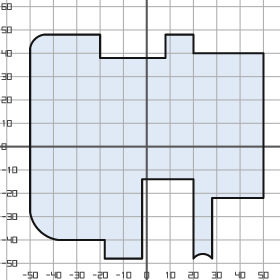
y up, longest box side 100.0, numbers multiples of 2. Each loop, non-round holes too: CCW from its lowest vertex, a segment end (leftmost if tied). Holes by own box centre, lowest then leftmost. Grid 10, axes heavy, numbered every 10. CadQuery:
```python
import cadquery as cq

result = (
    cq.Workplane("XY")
    .moveTo(-18.0, -48.0)
    .lineTo(-2.0, -48.0)
    .lineTo(-2.0, -14.0)
    .lineTo(20.0, -14.0)
    .lineTo(20.0, -48.0)
    .threePointArc((24.0, -46.0), (28.0, -48.0))
    .lineTo(28.0, -22.0)
    .lineTo(50.0, -22.0)
    .lineTo(50.0, 40.0)
    .lineTo(20.0, 40.0)
    .lineTo(20.0, 48.0)
    .lineTo(8.0, 48.0)
    .lineTo(8.0, 38.0)
    .lineTo(-20.0, 38.0)
    .lineTo(-20.0, 48.0)
    .lineTo(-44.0, 48.0)
    .threePointArc((-48.0, 46.0), (-50.0, 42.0))
    .lineTo(-50.0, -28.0)
    .threePointArc((-46.0, -36.0), (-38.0, -40.0))
    .lineTo(-18.0, -40.0)
    .close()
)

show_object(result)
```